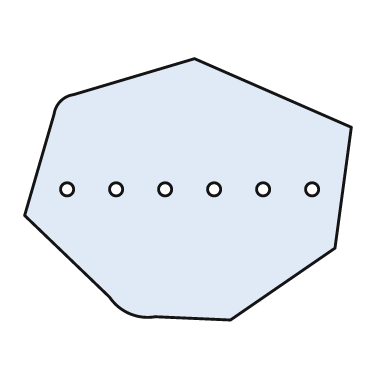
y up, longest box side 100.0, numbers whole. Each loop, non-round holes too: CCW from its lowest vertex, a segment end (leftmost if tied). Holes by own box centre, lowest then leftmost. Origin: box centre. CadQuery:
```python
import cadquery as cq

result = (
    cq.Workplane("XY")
    .moveTo(13.0, -40.0)
    .lineTo(45.0, -18.0)
    .lineTo(50.0, 19.0)
    .lineTo(2.0, 40.0)
    .lineTo(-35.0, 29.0)
    .threePointArc((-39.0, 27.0), (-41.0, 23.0))
    .lineTo(-50.0, -8.0)
    .lineTo(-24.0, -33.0)
    .threePointArc((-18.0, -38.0), (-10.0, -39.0))
    .close()
    .moveTo(-37.0, 0.0)
    .circle(2.0)
    .moveTo(-22.0, 0.0)
    .circle(2.0)
    .moveTo(-7.0, 0.0)
    .circle(2.0)
    .moveTo(8.0, 0.0)
    .circle(2.0)
    .moveTo(23.0, 0.0)
    .circle(2.0)
    .moveTo(38.0, 0.0)
    .circle(2.0)
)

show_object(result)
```